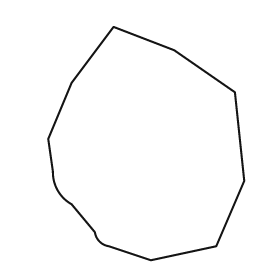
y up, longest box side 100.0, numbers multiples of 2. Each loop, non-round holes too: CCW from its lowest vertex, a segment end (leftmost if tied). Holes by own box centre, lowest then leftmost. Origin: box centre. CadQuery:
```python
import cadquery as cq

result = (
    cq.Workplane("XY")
    .moveTo(2.0, -50.0)
    .lineTo(30.0, -44.0)
    .lineTo(42.0, -16.0)
    .lineTo(38.0, 22.0)
    .lineTo(12.0, 40.0)
    .lineTo(-14.0, 50.0)
    .lineTo(-32.0, 26.0)
    .lineTo(-42.0, 2.0)
    .lineTo(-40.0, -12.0)
    .threePointArc((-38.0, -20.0), (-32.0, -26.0))
    .lineTo(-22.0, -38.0)
    .threePointArc((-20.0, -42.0), (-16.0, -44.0))
    .close()
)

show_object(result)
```